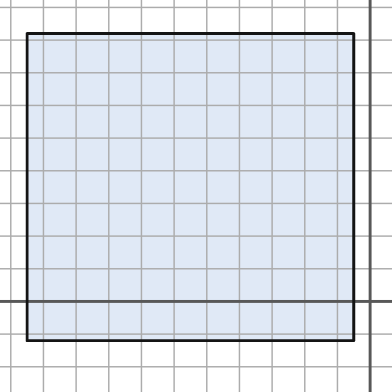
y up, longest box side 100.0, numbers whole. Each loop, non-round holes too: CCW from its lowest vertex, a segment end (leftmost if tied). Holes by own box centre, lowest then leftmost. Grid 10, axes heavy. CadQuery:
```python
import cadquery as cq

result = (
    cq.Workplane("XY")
    .moveTo(-105.0, -12.0)
    .lineTo(-5.0, -12.0)
    .lineTo(-5.0, 82.0)
    .lineTo(-105.0, 82.0)
    .close()
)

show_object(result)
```